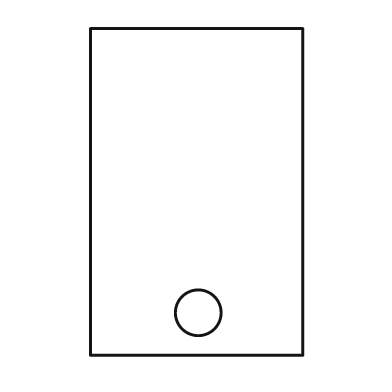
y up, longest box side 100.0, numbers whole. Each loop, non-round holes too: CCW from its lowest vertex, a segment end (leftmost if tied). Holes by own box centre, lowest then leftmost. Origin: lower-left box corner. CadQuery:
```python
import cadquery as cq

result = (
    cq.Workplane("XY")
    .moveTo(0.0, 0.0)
    .lineTo(65.0, 0.0)
    .lineTo(65.0, 100.0)
    .lineTo(0.0, 100.0)
    .close()
    .moveTo(33.0, 13.0)
    .circle(7.0)
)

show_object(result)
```